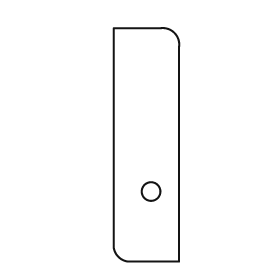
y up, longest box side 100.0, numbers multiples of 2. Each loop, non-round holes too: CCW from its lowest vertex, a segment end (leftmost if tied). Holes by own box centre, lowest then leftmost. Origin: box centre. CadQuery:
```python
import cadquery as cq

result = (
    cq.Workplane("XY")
    .moveTo(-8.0, -50.0)
    .lineTo(14.0, -50.0)
    .lineTo(14.0, 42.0)
    .threePointArc((12.0, 48.0), (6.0, 50.0))
    .lineTo(-14.0, 50.0)
    .lineTo(-14.0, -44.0)
    .threePointArc((-12.0, -48.0), (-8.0, -50.0))
    .close()
    .moveTo(2.0, -20.0)
    .circle(4.0)
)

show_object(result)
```